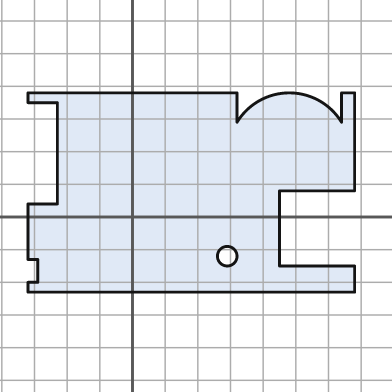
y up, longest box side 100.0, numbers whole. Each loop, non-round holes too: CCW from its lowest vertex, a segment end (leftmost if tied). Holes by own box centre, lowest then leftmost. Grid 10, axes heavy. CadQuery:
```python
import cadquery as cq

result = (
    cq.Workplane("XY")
    .moveTo(-32.0, -23.0)
    .lineTo(68.0, -23.0)
    .lineTo(68.0, -15.0)
    .lineTo(45.0, -15.0)
    .lineTo(45.0, 8.0)
    .lineTo(68.0, 8.0)
    .lineTo(68.0, 38.0)
    .lineTo(64.0, 38.0)
    .lineTo(64.0, 29.0)
    .threePointArc((48.0, 38.0), (32.0, 29.0))
    .lineTo(32.0, 38.0)
    .lineTo(-32.0, 38.0)
    .lineTo(-32.0, 35.0)
    .lineTo(-23.0, 35.0)
    .lineTo(-23.0, 4.0)
    .lineTo(-32.0, 4.0)
    .lineTo(-32.0, -13.0)
    .lineTo(-29.0, -13.0)
    .lineTo(-29.0, -20.0)
    .lineTo(-32.0, -20.0)
    .close()
    .moveTo(29.0, -12.0)
    .circle(3.0)
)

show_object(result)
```